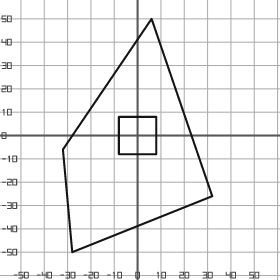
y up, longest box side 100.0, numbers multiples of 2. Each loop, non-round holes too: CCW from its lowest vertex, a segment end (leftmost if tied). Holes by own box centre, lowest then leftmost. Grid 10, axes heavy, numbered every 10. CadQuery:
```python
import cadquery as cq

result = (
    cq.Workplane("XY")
    .moveTo(-28.0, -50.0)
    .lineTo(32.0, -26.0)
    .lineTo(6.0, 50.0)
    .lineTo(-32.0, -6.0)
    .close()
    .moveTo(-8.0, -8.0)
    .lineTo(8.0, -8.0)
    .lineTo(8.0, 8.0)
    .lineTo(-8.0, 8.0)
    .close()
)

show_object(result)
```